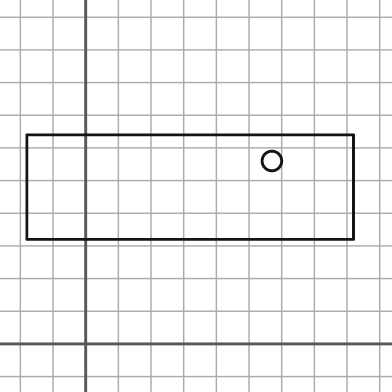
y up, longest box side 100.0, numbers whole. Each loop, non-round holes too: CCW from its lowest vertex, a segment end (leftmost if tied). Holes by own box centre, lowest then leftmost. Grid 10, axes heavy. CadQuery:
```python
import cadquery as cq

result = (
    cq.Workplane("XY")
    .moveTo(-18.0, 32.0)
    .lineTo(82.0, 32.0)
    .lineTo(82.0, 64.0)
    .lineTo(-18.0, 64.0)
    .close()
    .moveTo(57.0, 56.0)
    .circle(3.0)
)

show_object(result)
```